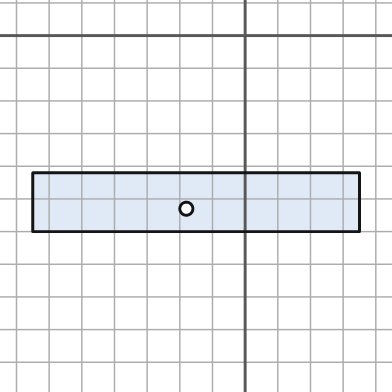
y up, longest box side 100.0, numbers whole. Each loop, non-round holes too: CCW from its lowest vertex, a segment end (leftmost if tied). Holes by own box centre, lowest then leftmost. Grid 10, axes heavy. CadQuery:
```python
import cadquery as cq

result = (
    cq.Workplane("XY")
    .moveTo(-65.0, -60.0)
    .lineTo(35.0, -60.0)
    .lineTo(35.0, -42.0)
    .lineTo(-65.0, -42.0)
    .close()
    .moveTo(-18.0, -53.0)
    .circle(2.0)
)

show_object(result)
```